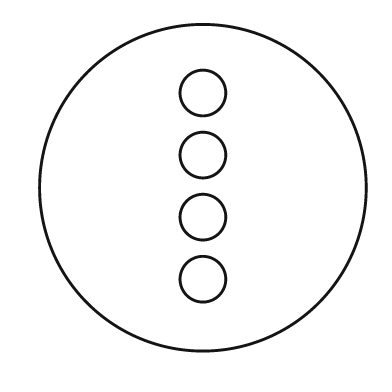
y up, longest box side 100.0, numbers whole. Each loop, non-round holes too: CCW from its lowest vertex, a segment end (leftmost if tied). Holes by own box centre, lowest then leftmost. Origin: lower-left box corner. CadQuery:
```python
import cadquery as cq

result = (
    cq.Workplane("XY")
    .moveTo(50.0, 50.0)
    .circle(50.0)
    .moveTo(50.0, 22.0)
    .circle(7.0)
    .moveTo(50.0, 41.0)
    .circle(7.0)
    .moveTo(50.0, 60.0)
    .circle(7.0)
    .moveTo(50.0, 79.0)
    .circle(7.0)
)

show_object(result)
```